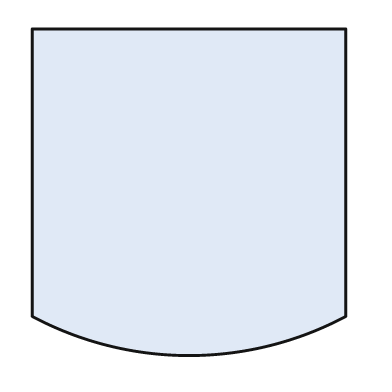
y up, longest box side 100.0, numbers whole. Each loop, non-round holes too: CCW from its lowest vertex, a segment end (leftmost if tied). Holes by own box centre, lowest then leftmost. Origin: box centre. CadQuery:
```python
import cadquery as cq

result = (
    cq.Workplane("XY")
    .moveTo(-48.0, -38.0)
    .threePointArc((0.0, -50.0), (48.0, -38.0))
    .lineTo(48.0, 50.0)
    .lineTo(-48.0, 50.0)
    .close()
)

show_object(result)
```